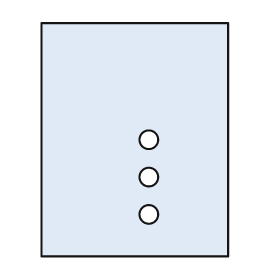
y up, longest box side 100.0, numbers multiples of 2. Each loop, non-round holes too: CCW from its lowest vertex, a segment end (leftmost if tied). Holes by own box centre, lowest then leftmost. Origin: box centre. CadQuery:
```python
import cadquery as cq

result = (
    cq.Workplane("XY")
    .moveTo(-40.0, -50.0)
    .lineTo(40.0, -50.0)
    .lineTo(40.0, 50.0)
    .lineTo(-40.0, 50.0)
    .close()
    .moveTo(6.0, -32.0)
    .circle(4.0)
    .moveTo(6.0, -16.0)
    .circle(4.0)
    .moveTo(6.0, 0.0)
    .circle(4.0)
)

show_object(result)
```